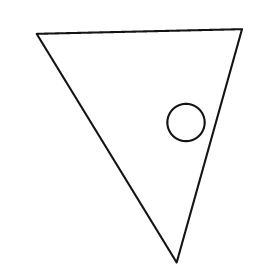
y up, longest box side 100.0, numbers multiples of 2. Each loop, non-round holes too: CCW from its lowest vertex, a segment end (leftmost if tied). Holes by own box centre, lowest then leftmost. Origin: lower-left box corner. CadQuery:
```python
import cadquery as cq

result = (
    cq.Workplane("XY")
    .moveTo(60.0, 0.0)
    .lineTo(88.0, 100.0)
    .lineTo(0.0, 98.0)
    .close()
    .moveTo(64.0, 60.0)
    .circle(8.0)
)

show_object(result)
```